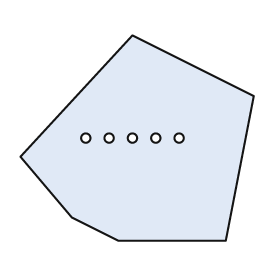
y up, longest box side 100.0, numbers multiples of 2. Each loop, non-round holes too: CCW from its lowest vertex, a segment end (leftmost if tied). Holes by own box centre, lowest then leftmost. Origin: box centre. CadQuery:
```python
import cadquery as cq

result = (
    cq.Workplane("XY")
    .moveTo(-8.0, -44.0)
    .lineTo(38.0, -44.0)
    .lineTo(50.0, 18.0)
    .lineTo(-2.0, 44.0)
    .lineTo(-50.0, -8.0)
    .lineTo(-28.0, -34.0)
    .close()
    .moveTo(-22.0, 0.0)
    .circle(2.0)
    .moveTo(-12.0, 0.0)
    .circle(2.0)
    .moveTo(-2.0, 0.0)
    .circle(2.0)
    .moveTo(8.0, 0.0)
    .circle(2.0)
    .moveTo(18.0, 0.0)
    .circle(2.0)
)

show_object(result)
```